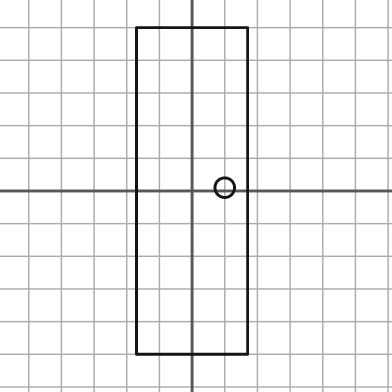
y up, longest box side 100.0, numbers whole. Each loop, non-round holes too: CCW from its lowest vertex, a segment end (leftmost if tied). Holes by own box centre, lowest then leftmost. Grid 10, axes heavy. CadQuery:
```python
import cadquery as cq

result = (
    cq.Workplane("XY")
    .moveTo(-17.0, -50.0)
    .lineTo(17.0, -50.0)
    .lineTo(17.0, 50.0)
    .lineTo(-17.0, 50.0)
    .close()
    .moveTo(10.0, 1.0)
    .circle(3.0)
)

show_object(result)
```